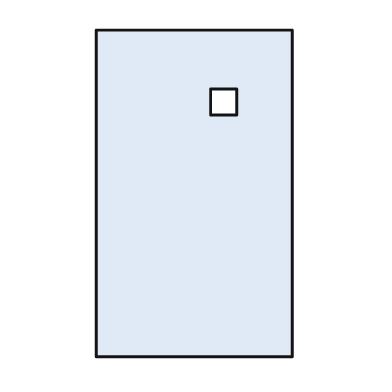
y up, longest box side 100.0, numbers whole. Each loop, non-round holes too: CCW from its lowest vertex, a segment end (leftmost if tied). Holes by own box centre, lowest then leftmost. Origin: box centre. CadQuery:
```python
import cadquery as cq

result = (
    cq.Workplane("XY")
    .moveTo(-30.0, -50.0)
    .lineTo(30.0, -50.0)
    .lineTo(30.0, 50.0)
    .lineTo(-30.0, 50.0)
    .close()
    .moveTo(5.0, 24.0)
    .lineTo(13.0, 24.0)
    .lineTo(13.0, 32.0)
    .lineTo(5.0, 32.0)
    .close()
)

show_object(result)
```